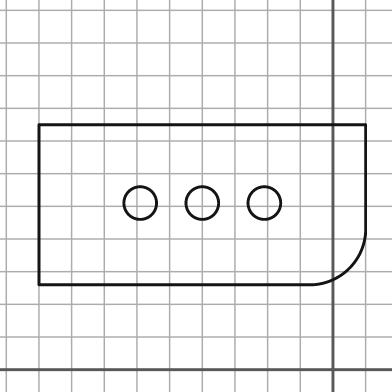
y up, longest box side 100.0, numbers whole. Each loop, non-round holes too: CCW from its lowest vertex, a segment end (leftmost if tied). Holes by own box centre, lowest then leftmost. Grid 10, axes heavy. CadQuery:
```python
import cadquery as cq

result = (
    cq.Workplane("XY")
    .moveTo(-90.0, 26.0)
    .lineTo(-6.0, 26.0)
    .threePointArc((5.0, 31.0), (10.0, 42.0))
    .lineTo(10.0, 75.0)
    .lineTo(-90.0, 75.0)
    .close()
    .moveTo(-59.0, 51.0)
    .circle(5.0)
    .moveTo(-40.0, 51.0)
    .circle(5.0)
    .moveTo(-21.0, 51.0)
    .circle(5.0)
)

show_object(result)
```